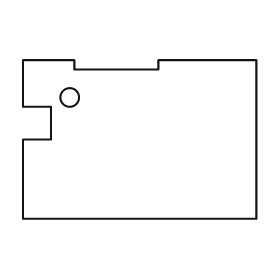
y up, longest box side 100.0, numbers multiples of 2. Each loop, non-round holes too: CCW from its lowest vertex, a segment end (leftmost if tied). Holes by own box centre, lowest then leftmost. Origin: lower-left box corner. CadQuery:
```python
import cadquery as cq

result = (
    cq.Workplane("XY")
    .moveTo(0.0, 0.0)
    .lineTo(100.0, 0.0)
    .lineTo(100.0, 68.0)
    .lineTo(58.0, 68.0)
    .lineTo(58.0, 64.0)
    .lineTo(22.0, 64.0)
    .lineTo(22.0, 68.0)
    .lineTo(0.0, 68.0)
    .lineTo(0.0, 48.0)
    .lineTo(12.0, 48.0)
    .lineTo(12.0, 34.0)
    .lineTo(0.0, 34.0)
    .close()
    .moveTo(20.0, 52.0)
    .circle(4.0)
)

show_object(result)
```